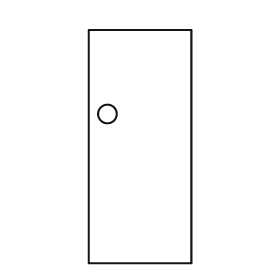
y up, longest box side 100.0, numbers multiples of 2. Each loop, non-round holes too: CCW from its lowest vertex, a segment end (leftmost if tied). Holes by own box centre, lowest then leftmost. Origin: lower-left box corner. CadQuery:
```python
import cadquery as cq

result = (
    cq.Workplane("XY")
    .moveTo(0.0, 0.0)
    .lineTo(44.0, 0.0)
    .lineTo(44.0, 100.0)
    .lineTo(0.0, 100.0)
    .close()
    .moveTo(8.0, 64.0)
    .circle(4.0)
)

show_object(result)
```